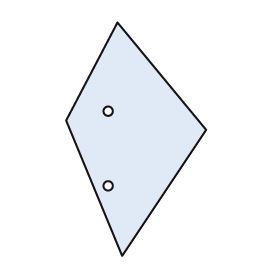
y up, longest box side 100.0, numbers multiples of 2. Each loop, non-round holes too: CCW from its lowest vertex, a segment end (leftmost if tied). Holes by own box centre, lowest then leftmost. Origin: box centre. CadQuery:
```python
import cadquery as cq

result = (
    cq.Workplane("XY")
    .moveTo(-6.0, -50.0)
    .lineTo(30.0, 4.0)
    .lineTo(-8.0, 50.0)
    .lineTo(-30.0, 8.0)
    .close()
    .moveTo(-12.0, -20.0)
    .circle(2.0)
    .moveTo(-12.0, 12.0)
    .circle(2.0)
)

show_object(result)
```